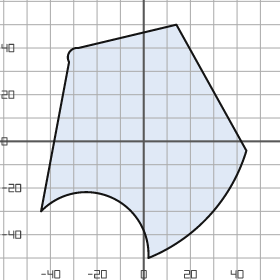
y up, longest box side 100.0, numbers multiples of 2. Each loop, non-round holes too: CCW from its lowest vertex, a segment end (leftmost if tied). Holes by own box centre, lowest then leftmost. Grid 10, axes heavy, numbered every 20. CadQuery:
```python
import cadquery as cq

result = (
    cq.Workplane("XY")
    .moveTo(2.0, -50.0)
    .threePointArc((28.0, -32.0), (44.0, -4.0))
    .lineTo(14.0, 50.0)
    .lineTo(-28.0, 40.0)
    .threePointArc((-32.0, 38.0), (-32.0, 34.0))
    .lineTo(-44.0, -30.0)
    .threePointArc((-14.0, -24.0), (2.0, -50.0))
    .close()
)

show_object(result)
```